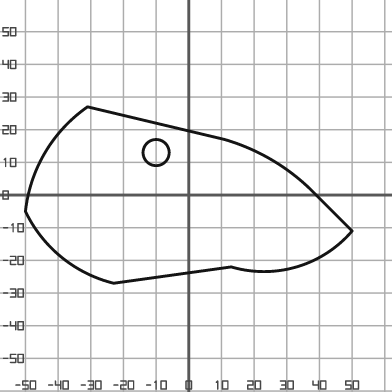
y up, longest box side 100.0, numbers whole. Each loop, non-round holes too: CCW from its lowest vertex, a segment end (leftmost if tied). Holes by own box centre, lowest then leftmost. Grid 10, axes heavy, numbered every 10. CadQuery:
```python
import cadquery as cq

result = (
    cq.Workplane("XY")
    .moveTo(-23.0, -27.0)
    .lineTo(13.0, -22.0)
    .threePointArc((33.0, -22.0), (50.0, -11.0))
    .lineTo(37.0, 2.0)
    .threePointArc((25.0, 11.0), (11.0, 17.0))
    .lineTo(-31.0, 27.0)
    .threePointArc((-44.0, 13.0), (-50.0, -5.0))
    .threePointArc((-39.0, -19.0), (-23.0, -27.0))
    .close()
    .moveTo(-10.0, 13.0)
    .circle(4.0)
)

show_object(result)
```